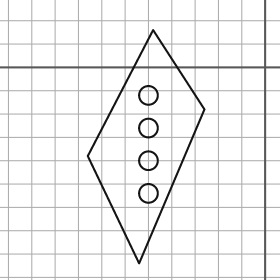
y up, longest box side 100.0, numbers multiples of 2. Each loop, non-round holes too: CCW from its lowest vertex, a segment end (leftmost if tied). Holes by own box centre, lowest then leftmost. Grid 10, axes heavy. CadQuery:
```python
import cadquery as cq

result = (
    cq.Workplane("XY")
    .moveTo(-54.0, -84.0)
    .lineTo(-26.0, -18.0)
    .lineTo(-48.0, 16.0)
    .lineTo(-76.0, -38.0)
    .close()
    .moveTo(-50.0, -54.0)
    .circle(4.0)
    .moveTo(-50.0, -40.0)
    .circle(4.0)
    .moveTo(-50.0, -26.0)
    .circle(4.0)
    .moveTo(-50.0, -12.0)
    .circle(4.0)
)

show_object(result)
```